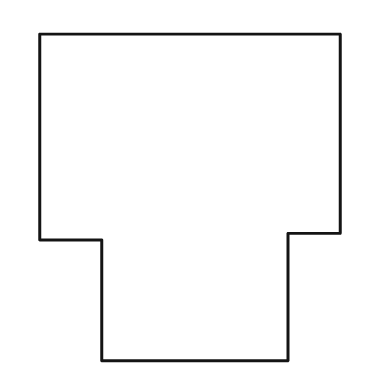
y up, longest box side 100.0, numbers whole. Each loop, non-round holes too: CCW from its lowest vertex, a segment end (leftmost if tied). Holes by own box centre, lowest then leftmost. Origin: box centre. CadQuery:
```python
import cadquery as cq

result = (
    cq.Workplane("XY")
    .moveTo(-27.0, -50.0)
    .lineTo(30.0, -50.0)
    .lineTo(30.0, -11.0)
    .lineTo(46.0, -11.0)
    .lineTo(46.0, 50.0)
    .lineTo(-46.0, 50.0)
    .lineTo(-46.0, -13.0)
    .lineTo(-27.0, -13.0)
    .close()
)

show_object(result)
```